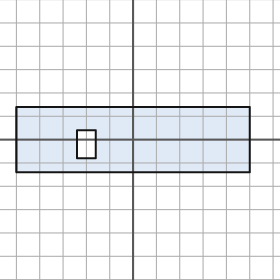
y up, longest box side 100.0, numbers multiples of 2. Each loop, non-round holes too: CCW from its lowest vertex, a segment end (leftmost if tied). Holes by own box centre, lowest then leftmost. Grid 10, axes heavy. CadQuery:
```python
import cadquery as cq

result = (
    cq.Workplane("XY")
    .moveTo(-50.0, -14.0)
    .lineTo(50.0, -14.0)
    .lineTo(50.0, 14.0)
    .lineTo(-50.0, 14.0)
    .close()
    .moveTo(-24.0, -8.0)
    .lineTo(-16.0, -8.0)
    .lineTo(-16.0, 4.0)
    .lineTo(-24.0, 4.0)
    .close()
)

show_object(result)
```